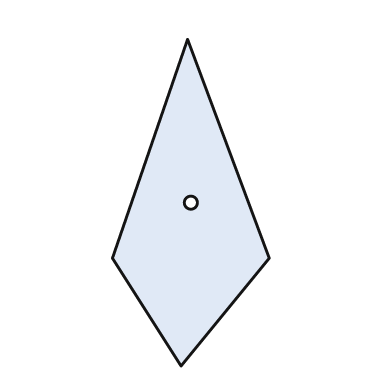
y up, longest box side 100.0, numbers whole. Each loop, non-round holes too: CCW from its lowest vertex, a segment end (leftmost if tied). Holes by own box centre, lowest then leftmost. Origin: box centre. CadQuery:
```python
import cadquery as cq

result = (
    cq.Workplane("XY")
    .moveTo(-3.0, -50.0)
    .lineTo(24.0, -17.0)
    .lineTo(-1.0, 50.0)
    .lineTo(-24.0, -17.0)
    .close()
    .moveTo(0.0, 0.0)
    .circle(2.0)
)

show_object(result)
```